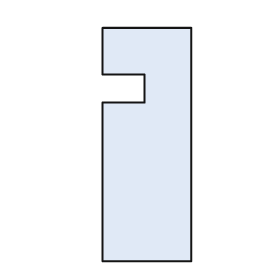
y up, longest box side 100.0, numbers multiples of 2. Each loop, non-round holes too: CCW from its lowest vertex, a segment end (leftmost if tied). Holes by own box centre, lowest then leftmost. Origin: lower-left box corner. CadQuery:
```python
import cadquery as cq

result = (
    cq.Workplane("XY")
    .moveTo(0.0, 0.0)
    .lineTo(38.0, 0.0)
    .lineTo(38.0, 100.0)
    .lineTo(0.0, 100.0)
    .lineTo(0.0, 80.0)
    .lineTo(18.0, 80.0)
    .lineTo(18.0, 68.0)
    .lineTo(0.0, 68.0)
    .close()
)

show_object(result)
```